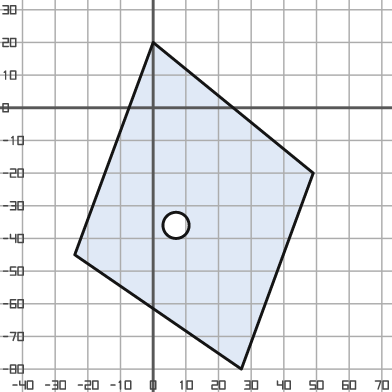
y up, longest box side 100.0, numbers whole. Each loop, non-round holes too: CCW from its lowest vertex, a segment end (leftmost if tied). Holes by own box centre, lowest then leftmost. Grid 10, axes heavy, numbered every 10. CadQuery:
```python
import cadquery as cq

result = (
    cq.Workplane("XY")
    .moveTo(27.0, -80.0)
    .lineTo(49.0, -20.0)
    .lineTo(0.0, 20.0)
    .lineTo(-24.0, -45.0)
    .close()
    .moveTo(7.0, -36.0)
    .circle(4.0)
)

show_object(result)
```